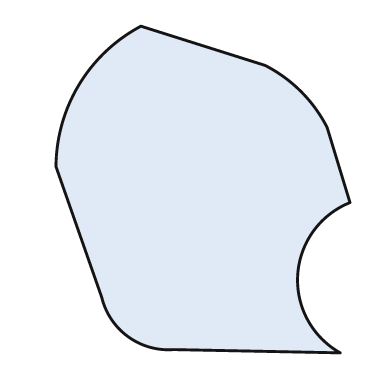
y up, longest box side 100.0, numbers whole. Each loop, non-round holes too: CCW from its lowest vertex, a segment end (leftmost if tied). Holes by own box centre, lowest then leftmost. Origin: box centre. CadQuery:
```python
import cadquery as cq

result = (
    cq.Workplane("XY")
    .moveTo(42.0, -50.0)
    .threePointArc((29.0, -26.0), (45.0, -4.0))
    .lineTo(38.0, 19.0)
    .threePointArc((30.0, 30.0), (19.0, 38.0))
    .lineTo(-19.0, 50.0)
    .threePointArc((-38.0, 32.0), (-45.0, 7.0))
    .lineTo(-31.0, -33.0)
    .threePointArc((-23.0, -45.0), (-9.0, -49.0))
    .close()
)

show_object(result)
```